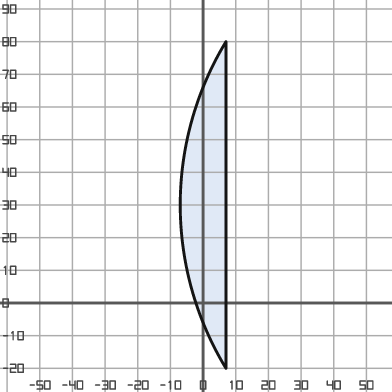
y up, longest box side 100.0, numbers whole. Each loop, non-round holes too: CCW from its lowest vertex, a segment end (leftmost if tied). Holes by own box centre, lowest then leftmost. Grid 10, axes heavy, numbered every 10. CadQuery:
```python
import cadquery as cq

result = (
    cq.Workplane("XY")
    .moveTo(7.0, -20.0)
    .lineTo(7.0, 80.0)
    .threePointArc((-7.0, 30.0), (7.0, -20.0))
    .close()
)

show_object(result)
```